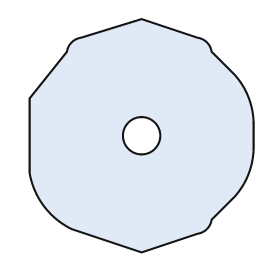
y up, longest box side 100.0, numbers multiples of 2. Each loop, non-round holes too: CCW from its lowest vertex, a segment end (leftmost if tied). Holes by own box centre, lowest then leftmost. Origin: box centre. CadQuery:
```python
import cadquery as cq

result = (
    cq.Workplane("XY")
    .moveTo(0.0, -50.0)
    .lineTo(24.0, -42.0)
    .threePointArc((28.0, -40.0), (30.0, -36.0))
    .lineTo(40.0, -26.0)
    .threePointArc((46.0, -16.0), (48.0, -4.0))
    .lineTo(48.0, 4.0)
    .threePointArc((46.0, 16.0), (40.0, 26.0))
    .lineTo(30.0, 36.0)
    .threePointArc((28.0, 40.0), (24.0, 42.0))
    .lineTo(0.0, 50.0)
    .lineTo(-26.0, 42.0)
    .threePointArc((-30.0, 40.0), (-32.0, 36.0))
    .lineTo(-48.0, 16.0)
    .lineTo(-48.0, -16.0)
    .threePointArc((-42.0, -30.0), (-30.0, -40.0))
    .close()
    .moveTo(0.0, 0.0)
    .circle(8.0)
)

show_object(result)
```